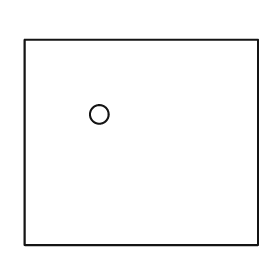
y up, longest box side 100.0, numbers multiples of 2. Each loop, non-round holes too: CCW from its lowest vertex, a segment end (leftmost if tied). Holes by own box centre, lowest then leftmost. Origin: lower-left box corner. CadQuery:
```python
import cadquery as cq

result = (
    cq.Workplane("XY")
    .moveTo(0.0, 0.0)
    .lineTo(100.0, 0.0)
    .lineTo(100.0, 88.0)
    .lineTo(0.0, 88.0)
    .close()
    .moveTo(32.0, 56.0)
    .circle(4.0)
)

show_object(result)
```